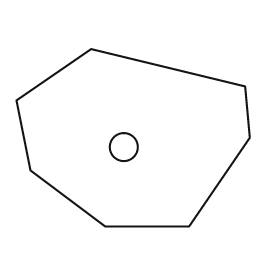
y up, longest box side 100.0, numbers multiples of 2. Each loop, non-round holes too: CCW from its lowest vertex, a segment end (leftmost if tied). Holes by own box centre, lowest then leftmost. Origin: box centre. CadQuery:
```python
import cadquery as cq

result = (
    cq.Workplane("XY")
    .moveTo(-12.0, -38.0)
    .lineTo(24.0, -38.0)
    .lineTo(50.0, 0.0)
    .lineTo(48.0, 22.0)
    .lineTo(-18.0, 38.0)
    .lineTo(-50.0, 16.0)
    .lineTo(-44.0, -14.0)
    .close()
    .moveTo(-4.0, -4.0)
    .circle(6.0)
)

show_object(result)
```